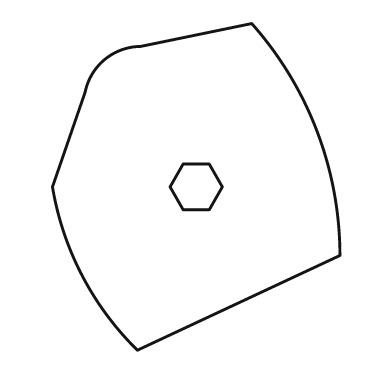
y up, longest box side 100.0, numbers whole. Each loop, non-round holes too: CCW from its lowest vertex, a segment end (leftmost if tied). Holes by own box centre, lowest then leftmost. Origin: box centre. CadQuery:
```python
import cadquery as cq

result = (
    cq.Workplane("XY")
    .moveTo(-18.0, -50.0)
    .lineTo(44.0, -21.0)
    .threePointArc((37.0, 17.0), (17.0, 50.0))
    .lineTo(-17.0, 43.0)
    .threePointArc((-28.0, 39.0), (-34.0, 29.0))
    .lineTo(-44.0, 0.0)
    .threePointArc((-35.0, -27.0), (-18.0, -50.0))
    .close()
    .moveTo(-4.0, -7.0)
    .lineTo(4.0, -7.0)
    .lineTo(8.0, 0.0)
    .lineTo(4.0, 7.0)
    .lineTo(-4.0, 7.0)
    .lineTo(-8.0, 0.0)
    .close()
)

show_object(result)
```